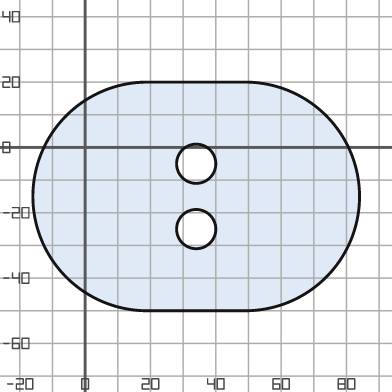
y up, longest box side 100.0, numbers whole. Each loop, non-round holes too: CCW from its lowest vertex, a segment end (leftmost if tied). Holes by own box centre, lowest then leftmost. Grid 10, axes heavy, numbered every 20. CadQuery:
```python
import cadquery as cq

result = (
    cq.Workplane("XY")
    .moveTo(19.0, -50.0)
    .lineTo(49.0, -50.0)
    .threePointArc((84.0, -15.0), (49.0, 20.0))
    .lineTo(19.0, 20.0)
    .threePointArc((-16.0, -15.0), (19.0, -50.0))
    .close()
    .moveTo(34.0, -25.0)
    .circle(6.0)
    .moveTo(34.0, -5.0)
    .circle(6.0)
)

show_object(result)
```